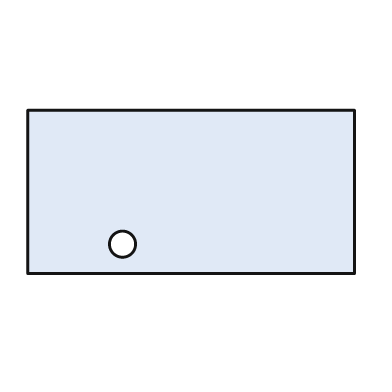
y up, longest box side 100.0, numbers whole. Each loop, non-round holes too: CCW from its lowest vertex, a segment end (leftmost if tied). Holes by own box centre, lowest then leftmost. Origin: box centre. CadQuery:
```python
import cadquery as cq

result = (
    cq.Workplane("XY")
    .moveTo(-50.0, -25.0)
    .lineTo(50.0, -25.0)
    .lineTo(50.0, 25.0)
    .lineTo(-50.0, 25.0)
    .close()
    .moveTo(-21.0, -16.0)
    .circle(4.0)
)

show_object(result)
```